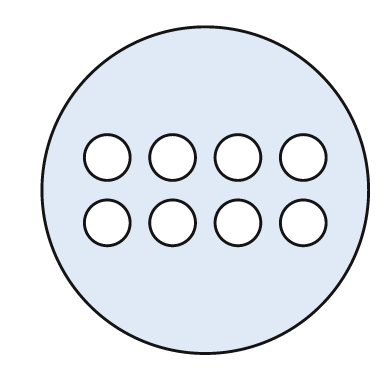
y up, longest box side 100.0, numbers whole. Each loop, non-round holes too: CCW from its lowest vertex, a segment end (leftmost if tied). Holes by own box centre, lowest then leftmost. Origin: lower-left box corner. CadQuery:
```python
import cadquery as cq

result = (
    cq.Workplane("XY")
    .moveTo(50.0, 50.0)
    .circle(50.0)
    .moveTo(20.0, 40.0)
    .circle(7.0)
    .moveTo(40.0, 40.0)
    .circle(7.0)
    .moveTo(60.0, 40.0)
    .circle(7.0)
    .moveTo(80.0, 40.0)
    .circle(7.0)
    .moveTo(20.0, 60.0)
    .circle(7.0)
    .moveTo(40.0, 60.0)
    .circle(7.0)
    .moveTo(60.0, 60.0)
    .circle(7.0)
    .moveTo(80.0, 60.0)
    .circle(7.0)
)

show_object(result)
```